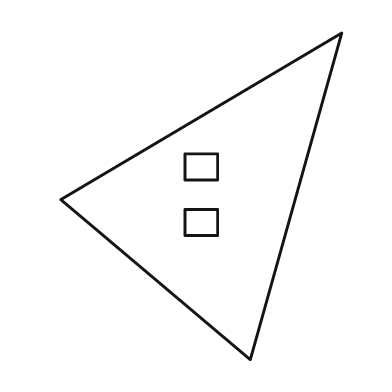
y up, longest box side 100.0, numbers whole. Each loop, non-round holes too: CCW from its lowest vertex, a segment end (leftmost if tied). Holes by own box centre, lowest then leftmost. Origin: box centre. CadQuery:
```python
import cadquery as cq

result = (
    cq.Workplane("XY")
    .moveTo(15.0, -50.0)
    .lineTo(43.0, 50.0)
    .lineTo(-43.0, -1.0)
    .close()
    .moveTo(-5.0, -12.0)
    .lineTo(5.0, -12.0)
    .lineTo(5.0, -4.0)
    .lineTo(-5.0, -4.0)
    .close()
    .moveTo(-5.0, 5.0)
    .lineTo(5.0, 5.0)
    .lineTo(5.0, 13.0)
    .lineTo(-5.0, 13.0)
    .close()
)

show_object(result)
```